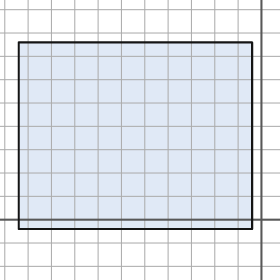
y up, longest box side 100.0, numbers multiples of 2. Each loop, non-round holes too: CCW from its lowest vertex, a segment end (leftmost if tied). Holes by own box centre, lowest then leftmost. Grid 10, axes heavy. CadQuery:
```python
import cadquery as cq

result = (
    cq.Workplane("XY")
    .moveTo(-104.0, -4.0)
    .lineTo(-4.0, -4.0)
    .lineTo(-4.0, 76.0)
    .lineTo(-104.0, 76.0)
    .close()
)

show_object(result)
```